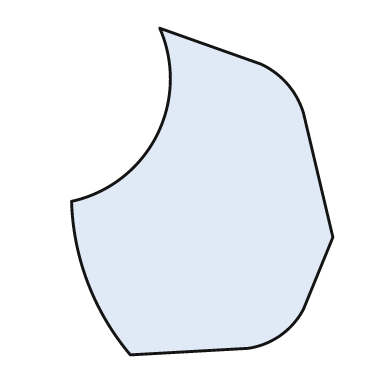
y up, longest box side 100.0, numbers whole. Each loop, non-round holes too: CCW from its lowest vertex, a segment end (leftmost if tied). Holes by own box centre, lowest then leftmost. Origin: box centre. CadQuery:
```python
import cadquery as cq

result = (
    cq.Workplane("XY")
    .moveTo(-22.0, -50.0)
    .lineTo(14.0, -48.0)
    .threePointArc((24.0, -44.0), (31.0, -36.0))
    .lineTo(40.0, -14.0)
    .lineTo(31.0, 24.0)
    .threePointArc((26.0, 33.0), (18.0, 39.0))
    .lineTo(-13.0, 50.0)
    .threePointArc((-14.0, 17.0), (-40.0, -3.0))
    .threePointArc((-35.0, -28.0), (-22.0, -50.0))
    .close()
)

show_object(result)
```